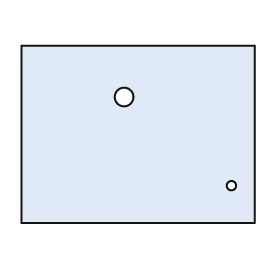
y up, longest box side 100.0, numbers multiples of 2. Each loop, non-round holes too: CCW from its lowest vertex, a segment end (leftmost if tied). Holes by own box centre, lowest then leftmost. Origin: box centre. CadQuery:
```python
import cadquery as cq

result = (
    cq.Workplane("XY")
    .moveTo(-50.0, -38.0)
    .lineTo(50.0, -38.0)
    .lineTo(50.0, 38.0)
    .lineTo(-50.0, 38.0)
    .close()
    .moveTo(40.0, -22.0)
    .circle(2.0)
    .moveTo(-6.0, 16.0)
    .circle(4.0)
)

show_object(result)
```